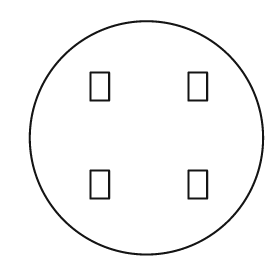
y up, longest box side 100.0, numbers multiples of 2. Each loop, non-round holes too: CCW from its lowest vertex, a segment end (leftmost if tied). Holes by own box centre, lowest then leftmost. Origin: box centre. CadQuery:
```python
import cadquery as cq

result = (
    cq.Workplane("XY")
    .moveTo(0.0, 0.0)
    .circle(50.0)
    .moveTo(-24.0, -26.0)
    .lineTo(-16.0, -26.0)
    .lineTo(-16.0, -14.0)
    .lineTo(-24.0, -14.0)
    .close()
    .moveTo(18.0, -26.0)
    .lineTo(26.0, -26.0)
    .lineTo(26.0, -14.0)
    .lineTo(18.0, -14.0)
    .close()
    .moveTo(-24.0, 16.0)
    .lineTo(-16.0, 16.0)
    .lineTo(-16.0, 28.0)
    .lineTo(-24.0, 28.0)
    .close()
    .moveTo(18.0, 16.0)
    .lineTo(26.0, 16.0)
    .lineTo(26.0, 28.0)
    .lineTo(18.0, 28.0)
    .close()
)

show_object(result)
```